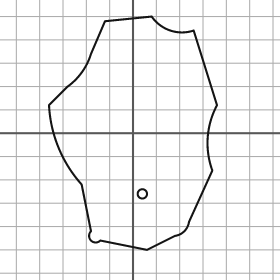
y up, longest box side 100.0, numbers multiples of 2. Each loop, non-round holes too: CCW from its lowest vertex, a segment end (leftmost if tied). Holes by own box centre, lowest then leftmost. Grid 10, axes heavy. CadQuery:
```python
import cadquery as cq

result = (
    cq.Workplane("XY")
    .moveTo(6.0, -50.0)
    .lineTo(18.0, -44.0)
    .threePointArc((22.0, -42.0), (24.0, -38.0))
    .lineTo(34.0, -16.0)
    .threePointArc((32.0, -2.0), (36.0, 12.0))
    .lineTo(26.0, 44.0)
    .threePointArc((16.0, 44.0), (8.0, 50.0))
    .lineTo(-12.0, 48.0)
    .lineTo(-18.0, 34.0)
    .threePointArc((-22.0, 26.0), (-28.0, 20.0))
    .lineTo(-36.0, 12.0)
    .threePointArc((-32.0, -6.0), (-22.0, -22.0))
    .lineTo(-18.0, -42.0)
    .threePointArc((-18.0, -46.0), (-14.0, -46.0))
    .close()
    .moveTo(4.0, -26.0)
    .circle(2.0)
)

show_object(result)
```